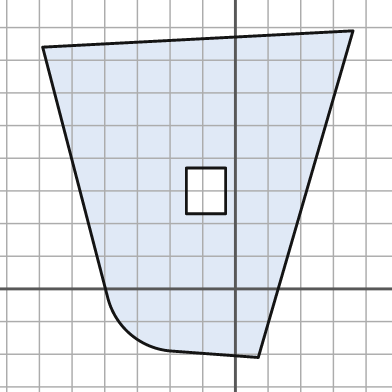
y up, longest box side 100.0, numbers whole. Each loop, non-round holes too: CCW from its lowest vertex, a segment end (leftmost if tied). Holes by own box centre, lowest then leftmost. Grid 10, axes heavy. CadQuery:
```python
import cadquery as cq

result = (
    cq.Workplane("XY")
    .moveTo(7.0, -21.0)
    .lineTo(36.0, 79.0)
    .lineTo(-59.0, 74.0)
    .lineTo(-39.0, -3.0)
    .threePointArc((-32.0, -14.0), (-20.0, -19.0))
    .close()
    .moveTo(-15.0, 23.0)
    .lineTo(-3.0, 23.0)
    .lineTo(-3.0, 37.0)
    .lineTo(-15.0, 37.0)
    .close()
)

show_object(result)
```